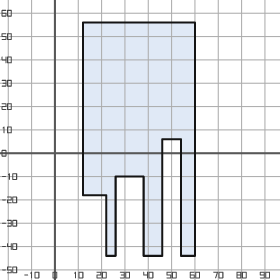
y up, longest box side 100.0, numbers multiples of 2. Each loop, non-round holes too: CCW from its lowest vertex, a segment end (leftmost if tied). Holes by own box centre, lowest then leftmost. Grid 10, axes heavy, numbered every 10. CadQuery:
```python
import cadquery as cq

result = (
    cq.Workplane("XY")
    .moveTo(22.0, -44.0)
    .lineTo(26.0, -44.0)
    .lineTo(26.0, -10.0)
    .lineTo(38.0, -10.0)
    .lineTo(38.0, -44.0)
    .lineTo(46.0, -44.0)
    .lineTo(46.0, 6.0)
    .lineTo(54.0, 6.0)
    .lineTo(54.0, -44.0)
    .lineTo(60.0, -44.0)
    .lineTo(60.0, 56.0)
    .lineTo(12.0, 56.0)
    .lineTo(12.0, -18.0)
    .lineTo(22.0, -18.0)
    .close()
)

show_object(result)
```